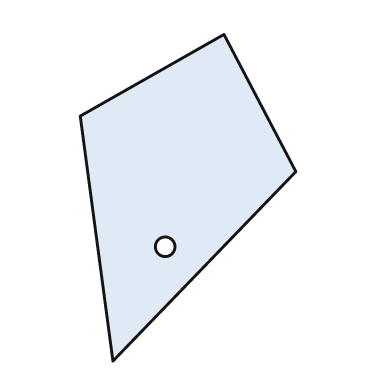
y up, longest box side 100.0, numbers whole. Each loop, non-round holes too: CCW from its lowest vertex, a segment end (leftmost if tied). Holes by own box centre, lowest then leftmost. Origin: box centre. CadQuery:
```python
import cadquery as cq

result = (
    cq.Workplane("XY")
    .moveTo(-23.0, -50.0)
    .lineTo(33.0, 8.0)
    .lineTo(11.0, 50.0)
    .lineTo(-33.0, 25.0)
    .close()
    .moveTo(-7.0, -15.0)
    .circle(3.0)
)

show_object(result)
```